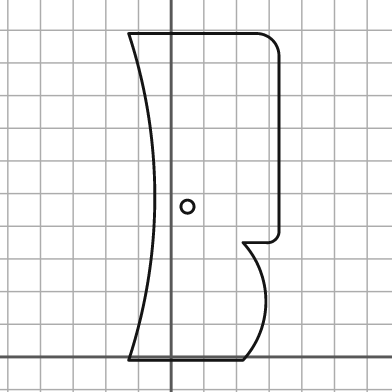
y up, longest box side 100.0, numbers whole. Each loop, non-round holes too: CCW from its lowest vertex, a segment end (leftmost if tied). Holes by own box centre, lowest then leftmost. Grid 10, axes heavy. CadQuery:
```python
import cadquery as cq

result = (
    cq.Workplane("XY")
    .moveTo(-13.0, -1.0)
    .lineTo(22.0, -1.0)
    .threePointArc((29.0, 17.0), (22.0, 35.0))
    .lineTo(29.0, 35.0)
    .threePointArc((32.0, 36.0), (33.0, 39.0))
    .lineTo(33.0, 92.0)
    .threePointArc((31.0, 97.0), (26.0, 99.0))
    .lineTo(-13.0, 99.0)
    .threePointArc((-5.0, 49.0), (-13.0, -1.0))
    .close()
    .moveTo(5.0, 46.0)
    .circle(2.0)
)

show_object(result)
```